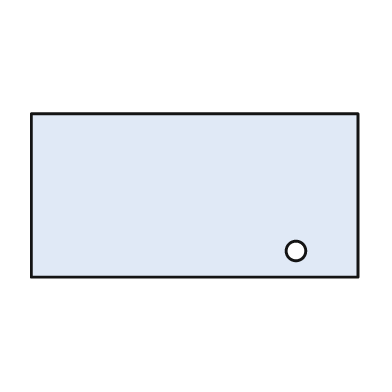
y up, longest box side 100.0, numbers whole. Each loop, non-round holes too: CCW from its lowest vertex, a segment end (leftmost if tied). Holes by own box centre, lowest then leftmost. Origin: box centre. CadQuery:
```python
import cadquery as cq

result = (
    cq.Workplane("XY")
    .moveTo(-50.0, -25.0)
    .lineTo(50.0, -25.0)
    .lineTo(50.0, 25.0)
    .lineTo(-50.0, 25.0)
    .close()
    .moveTo(31.0, -17.0)
    .circle(3.0)
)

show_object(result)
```